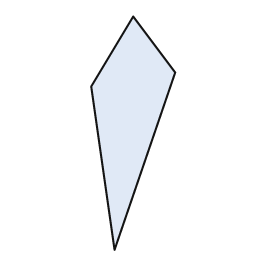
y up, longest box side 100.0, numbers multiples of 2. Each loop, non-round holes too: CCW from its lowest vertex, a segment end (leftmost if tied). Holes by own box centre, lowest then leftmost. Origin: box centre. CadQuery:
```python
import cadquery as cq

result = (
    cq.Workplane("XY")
    .moveTo(-8.0, -50.0)
    .lineTo(18.0, 26.0)
    .lineTo(0.0, 50.0)
    .lineTo(-18.0, 20.0)
    .close()
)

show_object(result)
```